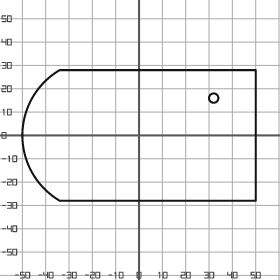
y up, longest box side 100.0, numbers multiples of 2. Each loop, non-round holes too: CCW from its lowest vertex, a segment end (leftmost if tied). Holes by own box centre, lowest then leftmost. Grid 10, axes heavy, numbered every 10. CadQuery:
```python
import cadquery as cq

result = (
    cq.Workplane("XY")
    .moveTo(-34.0, -28.0)
    .lineTo(50.0, -28.0)
    .lineTo(50.0, 28.0)
    .lineTo(-34.0, 28.0)
    .threePointArc((-50.0, 0.0), (-34.0, -28.0))
    .close()
    .moveTo(32.0, 16.0)
    .circle(2.0)
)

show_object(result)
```